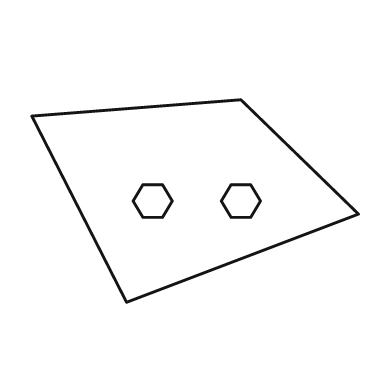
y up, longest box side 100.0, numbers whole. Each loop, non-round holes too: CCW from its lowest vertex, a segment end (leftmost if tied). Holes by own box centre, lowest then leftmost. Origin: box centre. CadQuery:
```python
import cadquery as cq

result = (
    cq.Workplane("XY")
    .moveTo(-21.0, -31.0)
    .lineTo(50.0, -4.0)
    .lineTo(14.0, 31.0)
    .lineTo(-50.0, 26.0)
    .close()
    .moveTo(-16.0, -5.0)
    .lineTo(-10.0, -5.0)
    .lineTo(-7.0, 0.0)
    .lineTo(-10.0, 5.0)
    .lineTo(-16.0, 5.0)
    .lineTo(-19.0, 0.0)
    .close()
    .moveTo(11.0, -5.0)
    .lineTo(17.0, -5.0)
    .lineTo(20.0, 0.0)
    .lineTo(17.0, 5.0)
    .lineTo(11.0, 5.0)
    .lineTo(8.0, 0.0)
    .close()
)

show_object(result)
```